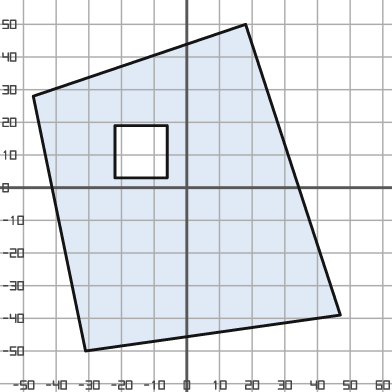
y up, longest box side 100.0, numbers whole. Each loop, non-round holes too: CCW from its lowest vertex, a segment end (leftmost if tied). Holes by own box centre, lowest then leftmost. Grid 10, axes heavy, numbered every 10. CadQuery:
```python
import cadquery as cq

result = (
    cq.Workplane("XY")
    .moveTo(-31.0, -50.0)
    .lineTo(47.0, -39.0)
    .lineTo(18.0, 50.0)
    .lineTo(-47.0, 28.0)
    .close()
    .moveTo(-22.0, 3.0)
    .lineTo(-6.0, 3.0)
    .lineTo(-6.0, 19.0)
    .lineTo(-22.0, 19.0)
    .close()
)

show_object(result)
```